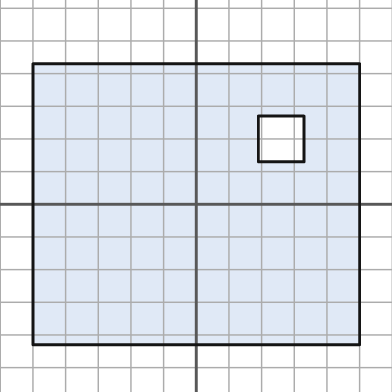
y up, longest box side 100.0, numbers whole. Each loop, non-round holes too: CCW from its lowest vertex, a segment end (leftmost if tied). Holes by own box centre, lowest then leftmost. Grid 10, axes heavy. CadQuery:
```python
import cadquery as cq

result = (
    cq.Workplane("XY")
    .moveTo(-50.0, -43.0)
    .lineTo(50.0, -43.0)
    .lineTo(50.0, 43.0)
    .lineTo(-50.0, 43.0)
    .close()
    .moveTo(19.0, 13.0)
    .lineTo(33.0, 13.0)
    .lineTo(33.0, 27.0)
    .lineTo(19.0, 27.0)
    .close()
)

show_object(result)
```